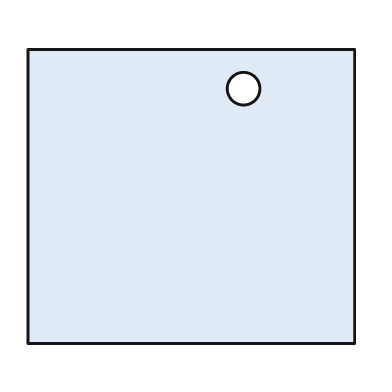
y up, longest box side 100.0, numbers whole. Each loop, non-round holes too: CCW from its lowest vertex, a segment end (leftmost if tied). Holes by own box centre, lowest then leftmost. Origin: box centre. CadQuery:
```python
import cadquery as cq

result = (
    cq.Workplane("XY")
    .moveTo(-50.0, -45.0)
    .lineTo(50.0, -45.0)
    .lineTo(50.0, 45.0)
    .lineTo(-50.0, 45.0)
    .close()
    .moveTo(16.0, 33.0)
    .circle(5.0)
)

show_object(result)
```